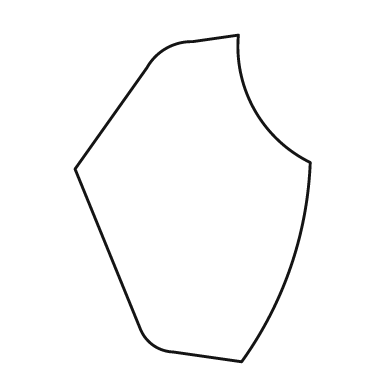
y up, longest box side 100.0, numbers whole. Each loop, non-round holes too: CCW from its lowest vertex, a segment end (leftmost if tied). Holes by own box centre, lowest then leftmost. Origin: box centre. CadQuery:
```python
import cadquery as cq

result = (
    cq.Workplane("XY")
    .moveTo(15.0, -50.0)
    .threePointArc((30.0, -21.0), (36.0, 11.0))
    .threePointArc((19.0, 27.0), (14.0, 50.0))
    .lineTo(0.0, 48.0)
    .threePointArc((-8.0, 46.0), (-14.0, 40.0))
    .lineTo(-36.0, 9.0)
    .lineTo(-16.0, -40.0)
    .threePointArc((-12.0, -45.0), (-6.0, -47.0))
    .close()
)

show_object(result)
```